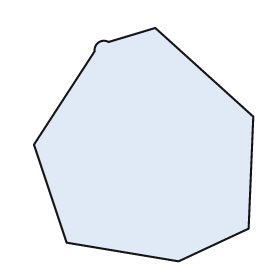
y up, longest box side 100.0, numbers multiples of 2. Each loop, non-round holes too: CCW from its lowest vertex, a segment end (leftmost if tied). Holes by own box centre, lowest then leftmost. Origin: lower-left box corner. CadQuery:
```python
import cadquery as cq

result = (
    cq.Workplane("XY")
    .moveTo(62.0, 0.0)
    .lineTo(92.0, 14.0)
    .lineTo(94.0, 62.0)
    .lineTo(52.0, 100.0)
    .lineTo(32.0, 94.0)
    .threePointArc((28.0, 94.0), (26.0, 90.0))
    .lineTo(0.0, 50.0)
    .lineTo(14.0, 8.0)
    .close()
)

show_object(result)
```